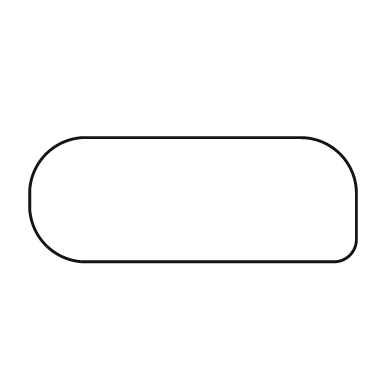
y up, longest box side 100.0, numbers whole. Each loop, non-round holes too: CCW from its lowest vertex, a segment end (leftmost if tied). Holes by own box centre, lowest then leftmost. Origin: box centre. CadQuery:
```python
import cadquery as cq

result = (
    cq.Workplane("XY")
    .moveTo(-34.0, -19.0)
    .lineTo(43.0, -19.0)
    .threePointArc((48.0, -17.0), (50.0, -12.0))
    .lineTo(50.0, 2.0)
    .threePointArc((45.0, 14.0), (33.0, 19.0))
    .lineTo(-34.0, 19.0)
    .threePointArc((-45.0, 14.0), (-50.0, 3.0))
    .lineTo(-50.0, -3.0)
    .threePointArc((-45.0, -14.0), (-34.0, -19.0))
    .close()
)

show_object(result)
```